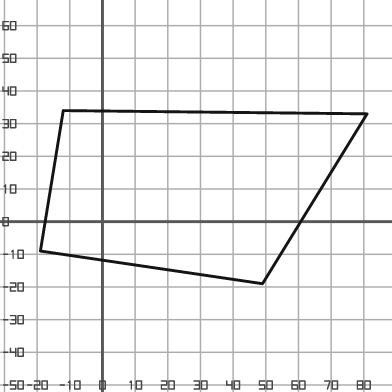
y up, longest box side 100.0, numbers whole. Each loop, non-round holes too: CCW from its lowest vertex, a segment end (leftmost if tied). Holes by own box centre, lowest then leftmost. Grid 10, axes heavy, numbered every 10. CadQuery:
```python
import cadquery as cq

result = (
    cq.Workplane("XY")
    .moveTo(49.0, -19.0)
    .lineTo(81.0, 33.0)
    .lineTo(-12.0, 34.0)
    .lineTo(-19.0, -9.0)
    .close()
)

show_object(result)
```